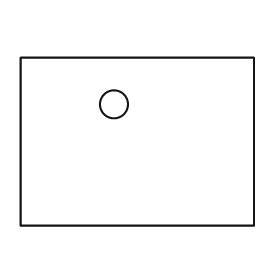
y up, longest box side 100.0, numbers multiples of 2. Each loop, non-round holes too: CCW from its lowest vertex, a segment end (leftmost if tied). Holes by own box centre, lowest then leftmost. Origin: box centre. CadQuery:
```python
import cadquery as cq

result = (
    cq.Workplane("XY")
    .moveTo(-50.0, -36.0)
    .lineTo(50.0, -36.0)
    .lineTo(50.0, 36.0)
    .lineTo(-50.0, 36.0)
    .close()
    .moveTo(-10.0, 16.0)
    .circle(6.0)
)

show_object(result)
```